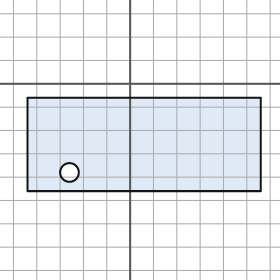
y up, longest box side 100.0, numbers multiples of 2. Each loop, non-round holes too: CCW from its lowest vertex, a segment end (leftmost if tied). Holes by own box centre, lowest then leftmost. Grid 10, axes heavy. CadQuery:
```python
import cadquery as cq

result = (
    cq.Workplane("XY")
    .moveTo(-44.0, -46.0)
    .lineTo(56.0, -46.0)
    .lineTo(56.0, -6.0)
    .lineTo(-44.0, -6.0)
    .close()
    .moveTo(-26.0, -38.0)
    .circle(4.0)
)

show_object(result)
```